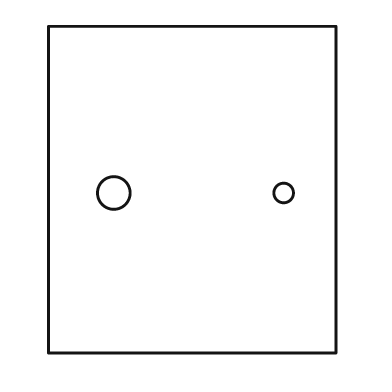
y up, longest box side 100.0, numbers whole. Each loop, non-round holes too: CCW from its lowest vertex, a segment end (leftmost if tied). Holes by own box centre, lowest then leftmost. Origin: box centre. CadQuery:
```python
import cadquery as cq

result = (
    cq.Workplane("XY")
    .moveTo(-44.0, -50.0)
    .lineTo(44.0, -50.0)
    .lineTo(44.0, 50.0)
    .lineTo(-44.0, 50.0)
    .close()
    .moveTo(-24.0, -1.0)
    .circle(5.0)
    .moveTo(28.0, -1.0)
    .circle(3.0)
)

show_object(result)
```